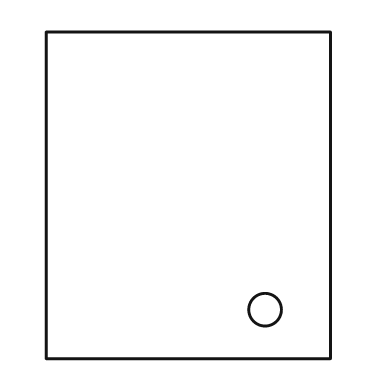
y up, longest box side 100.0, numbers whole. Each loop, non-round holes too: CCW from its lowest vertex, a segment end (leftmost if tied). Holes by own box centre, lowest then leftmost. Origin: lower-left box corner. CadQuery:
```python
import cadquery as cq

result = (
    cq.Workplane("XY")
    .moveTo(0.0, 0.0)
    .lineTo(87.0, 0.0)
    .lineTo(87.0, 100.0)
    .lineTo(0.0, 100.0)
    .close()
    .moveTo(67.0, 15.0)
    .circle(5.0)
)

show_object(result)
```